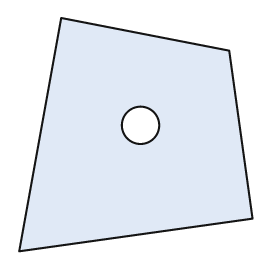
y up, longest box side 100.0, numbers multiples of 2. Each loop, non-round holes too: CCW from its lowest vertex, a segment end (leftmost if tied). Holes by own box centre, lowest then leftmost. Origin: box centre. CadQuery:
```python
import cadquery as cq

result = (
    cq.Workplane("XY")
    .moveTo(-50.0, -50.0)
    .lineTo(50.0, -36.0)
    .lineTo(40.0, 36.0)
    .lineTo(-32.0, 50.0)
    .close()
    .moveTo(2.0, 4.0)
    .circle(8.0)
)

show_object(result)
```